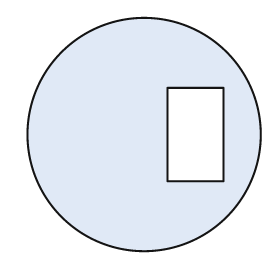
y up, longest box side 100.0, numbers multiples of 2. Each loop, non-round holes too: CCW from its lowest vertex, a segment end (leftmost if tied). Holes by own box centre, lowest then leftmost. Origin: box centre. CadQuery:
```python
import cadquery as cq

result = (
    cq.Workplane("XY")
    .moveTo(0.0, 0.0)
    .circle(50.0)
    .moveTo(10.0, -20.0)
    .lineTo(34.0, -20.0)
    .lineTo(34.0, 20.0)
    .lineTo(10.0, 20.0)
    .close()
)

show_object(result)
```